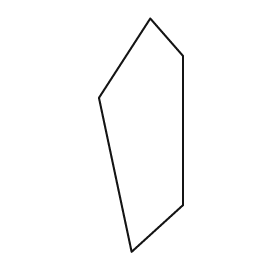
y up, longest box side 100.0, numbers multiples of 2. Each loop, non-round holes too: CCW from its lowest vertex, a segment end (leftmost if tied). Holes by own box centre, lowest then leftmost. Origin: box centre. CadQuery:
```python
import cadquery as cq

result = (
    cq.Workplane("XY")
    .moveTo(-4.0, -50.0)
    .lineTo(18.0, -30.0)
    .lineTo(18.0, 34.0)
    .lineTo(4.0, 50.0)
    .lineTo(-18.0, 16.0)
    .close()
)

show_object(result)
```